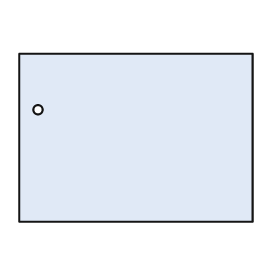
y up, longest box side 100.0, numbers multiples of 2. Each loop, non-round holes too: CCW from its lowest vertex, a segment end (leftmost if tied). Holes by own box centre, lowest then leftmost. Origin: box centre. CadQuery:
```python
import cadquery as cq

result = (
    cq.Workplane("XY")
    .moveTo(-50.0, -36.0)
    .lineTo(50.0, -36.0)
    .lineTo(50.0, 36.0)
    .lineTo(-50.0, 36.0)
    .close()
    .moveTo(-42.0, 12.0)
    .circle(2.0)
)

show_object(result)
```